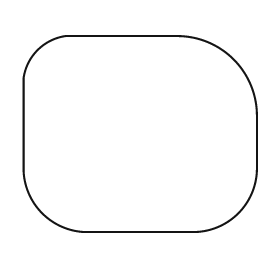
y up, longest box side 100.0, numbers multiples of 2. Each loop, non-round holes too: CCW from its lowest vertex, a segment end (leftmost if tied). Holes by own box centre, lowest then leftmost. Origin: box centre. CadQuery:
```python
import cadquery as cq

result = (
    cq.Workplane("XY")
    .moveTo(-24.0, -42.0)
    .lineTo(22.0, -42.0)
    .threePointArc((42.0, -34.0), (50.0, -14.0))
    .lineTo(50.0, 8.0)
    .threePointArc((40.0, 32.0), (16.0, 42.0))
    .lineTo(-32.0, 42.0)
    .threePointArc((-44.0, 36.0), (-50.0, 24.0))
    .lineTo(-50.0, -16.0)
    .threePointArc((-42.0, -34.0), (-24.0, -42.0))
    .close()
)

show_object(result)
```